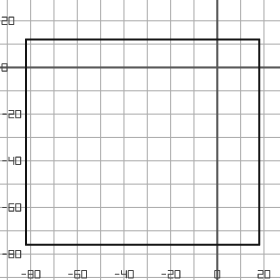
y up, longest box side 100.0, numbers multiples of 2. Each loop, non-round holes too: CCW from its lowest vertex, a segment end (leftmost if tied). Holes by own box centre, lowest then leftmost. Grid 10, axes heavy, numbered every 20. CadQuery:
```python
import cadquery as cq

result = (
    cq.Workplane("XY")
    .moveTo(-82.0, -76.0)
    .lineTo(18.0, -76.0)
    .lineTo(18.0, 12.0)
    .lineTo(-82.0, 12.0)
    .close()
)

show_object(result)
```